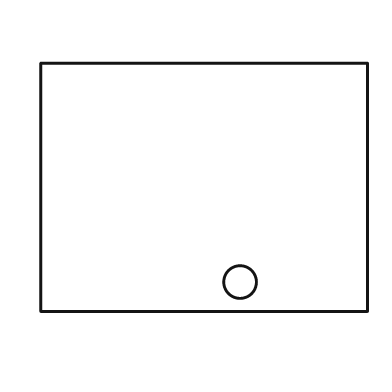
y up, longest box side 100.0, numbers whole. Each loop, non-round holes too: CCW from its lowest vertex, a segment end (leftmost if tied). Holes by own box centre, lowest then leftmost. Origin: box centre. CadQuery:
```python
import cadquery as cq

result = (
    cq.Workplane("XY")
    .moveTo(-50.0, -38.0)
    .lineTo(50.0, -38.0)
    .lineTo(50.0, 38.0)
    .lineTo(-50.0, 38.0)
    .close()
    .moveTo(11.0, -29.0)
    .circle(5.0)
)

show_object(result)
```